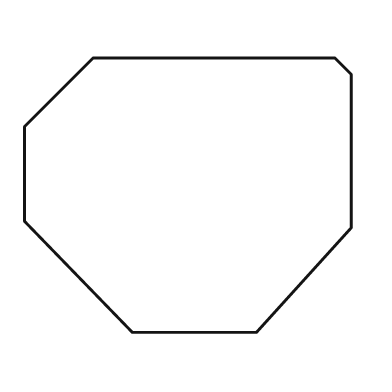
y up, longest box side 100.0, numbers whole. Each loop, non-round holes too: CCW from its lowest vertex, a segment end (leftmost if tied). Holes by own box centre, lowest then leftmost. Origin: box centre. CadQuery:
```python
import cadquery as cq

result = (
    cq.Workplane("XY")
    .moveTo(-17.0, -42.0)
    .lineTo(21.0, -42.0)
    .lineTo(50.0, -10.0)
    .lineTo(50.0, 37.0)
    .lineTo(45.0, 42.0)
    .lineTo(-29.0, 42.0)
    .lineTo(-50.0, 21.0)
    .lineTo(-50.0, -8.0)
    .close()
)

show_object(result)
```